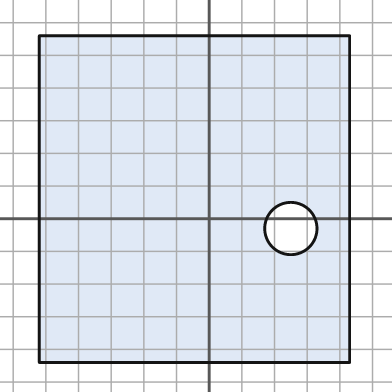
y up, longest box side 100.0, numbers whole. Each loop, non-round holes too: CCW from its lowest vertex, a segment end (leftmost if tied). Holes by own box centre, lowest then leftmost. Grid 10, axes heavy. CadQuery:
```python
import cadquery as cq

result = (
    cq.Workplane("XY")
    .moveTo(-52.0, -44.0)
    .lineTo(43.0, -44.0)
    .lineTo(43.0, 56.0)
    .lineTo(-52.0, 56.0)
    .close()
    .moveTo(25.0, -3.0)
    .circle(8.0)
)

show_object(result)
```